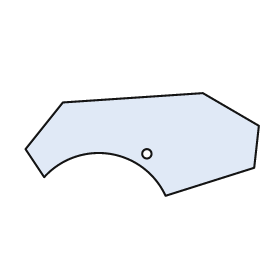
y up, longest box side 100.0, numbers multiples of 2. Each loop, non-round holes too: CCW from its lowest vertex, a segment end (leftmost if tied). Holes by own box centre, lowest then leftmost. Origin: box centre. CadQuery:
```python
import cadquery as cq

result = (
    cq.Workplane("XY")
    .moveTo(10.0, -22.0)
    .lineTo(48.0, -10.0)
    .lineTo(50.0, 8.0)
    .lineTo(26.0, 22.0)
    .lineTo(-34.0, 18.0)
    .lineTo(-50.0, -2.0)
    .lineTo(-42.0, -14.0)
    .threePointArc((-14.0, -4.0), (10.0, -22.0))
    .close()
    .moveTo(2.0, -4.0)
    .circle(2.0)
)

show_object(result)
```